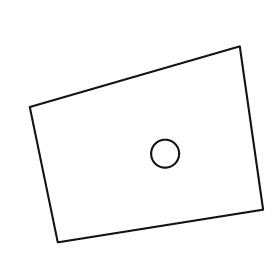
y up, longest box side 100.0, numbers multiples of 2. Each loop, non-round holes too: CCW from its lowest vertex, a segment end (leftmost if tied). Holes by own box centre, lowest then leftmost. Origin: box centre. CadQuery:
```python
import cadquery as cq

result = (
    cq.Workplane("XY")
    .moveTo(-38.0, -42.0)
    .lineTo(50.0, -28.0)
    .lineTo(40.0, 42.0)
    .lineTo(-50.0, 16.0)
    .close()
    .moveTo(8.0, -4.0)
    .circle(6.0)
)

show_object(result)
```